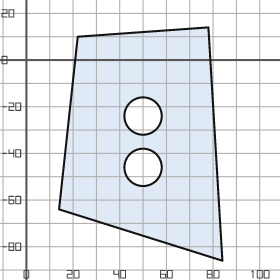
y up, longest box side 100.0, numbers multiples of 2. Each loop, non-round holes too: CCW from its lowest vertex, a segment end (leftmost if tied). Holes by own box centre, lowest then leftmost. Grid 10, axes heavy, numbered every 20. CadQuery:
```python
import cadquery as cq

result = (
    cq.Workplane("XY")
    .moveTo(84.0, -86.0)
    .lineTo(78.0, 14.0)
    .lineTo(22.0, 10.0)
    .lineTo(14.0, -64.0)
    .close()
    .moveTo(50.0, -46.0)
    .circle(8.0)
    .moveTo(50.0, -24.0)
    .circle(8.0)
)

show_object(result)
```